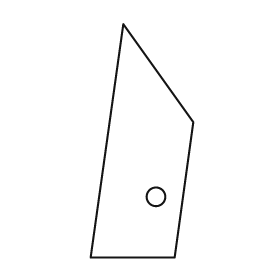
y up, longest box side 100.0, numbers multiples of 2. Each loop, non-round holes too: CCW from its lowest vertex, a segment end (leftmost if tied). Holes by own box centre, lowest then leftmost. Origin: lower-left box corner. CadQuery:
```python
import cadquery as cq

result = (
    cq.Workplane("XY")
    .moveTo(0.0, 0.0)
    .lineTo(36.0, 0.0)
    .lineTo(44.0, 58.0)
    .lineTo(14.0, 100.0)
    .close()
    .moveTo(28.0, 26.0)
    .circle(4.0)
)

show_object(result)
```